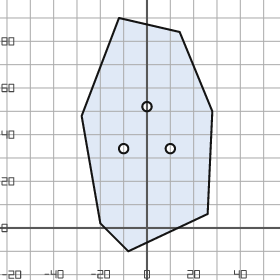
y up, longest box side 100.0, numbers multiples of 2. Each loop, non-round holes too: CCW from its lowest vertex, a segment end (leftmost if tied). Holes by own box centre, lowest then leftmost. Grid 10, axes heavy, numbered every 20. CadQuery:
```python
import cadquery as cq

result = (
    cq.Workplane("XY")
    .moveTo(-8.0, -10.0)
    .lineTo(26.0, 6.0)
    .lineTo(28.0, 50.0)
    .lineTo(14.0, 84.0)
    .lineTo(-12.0, 90.0)
    .lineTo(-28.0, 48.0)
    .lineTo(-20.0, 2.0)
    .close()
    .moveTo(-10.0, 34.0)
    .circle(2.0)
    .moveTo(10.0, 34.0)
    .circle(2.0)
    .moveTo(0.0, 52.0)
    .circle(2.0)
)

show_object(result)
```